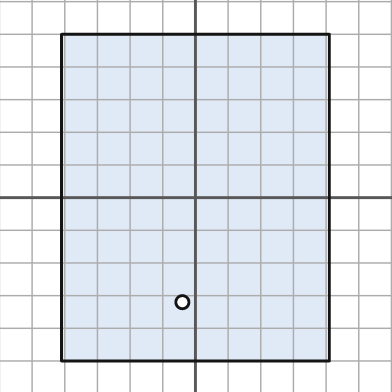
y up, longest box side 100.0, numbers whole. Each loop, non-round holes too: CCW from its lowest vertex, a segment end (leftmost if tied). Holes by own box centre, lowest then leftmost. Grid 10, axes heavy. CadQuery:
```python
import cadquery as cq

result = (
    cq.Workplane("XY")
    .moveTo(-41.0, -50.0)
    .lineTo(41.0, -50.0)
    .lineTo(41.0, 50.0)
    .lineTo(-41.0, 50.0)
    .close()
    .moveTo(-4.0, -32.0)
    .circle(2.0)
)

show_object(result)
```